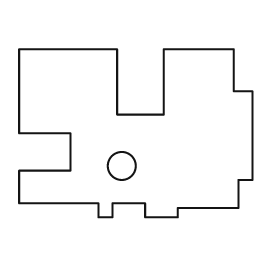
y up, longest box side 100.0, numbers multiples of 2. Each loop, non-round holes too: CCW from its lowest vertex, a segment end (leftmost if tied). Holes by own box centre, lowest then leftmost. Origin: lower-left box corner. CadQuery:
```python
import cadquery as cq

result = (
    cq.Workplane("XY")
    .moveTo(34.0, 0.0)
    .lineTo(40.0, 0.0)
    .lineTo(40.0, 6.0)
    .lineTo(54.0, 6.0)
    .lineTo(54.0, 0.0)
    .lineTo(68.0, 0.0)
    .lineTo(68.0, 4.0)
    .lineTo(94.0, 4.0)
    .lineTo(94.0, 16.0)
    .lineTo(100.0, 16.0)
    .lineTo(100.0, 54.0)
    .lineTo(92.0, 54.0)
    .lineTo(92.0, 72.0)
    .lineTo(62.0, 72.0)
    .lineTo(62.0, 44.0)
    .lineTo(42.0, 44.0)
    .lineTo(42.0, 72.0)
    .lineTo(0.0, 72.0)
    .lineTo(0.0, 36.0)
    .lineTo(22.0, 36.0)
    .lineTo(22.0, 20.0)
    .lineTo(0.0, 20.0)
    .lineTo(0.0, 6.0)
    .lineTo(34.0, 6.0)
    .close()
    .moveTo(44.0, 22.0)
    .circle(6.0)
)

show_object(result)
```